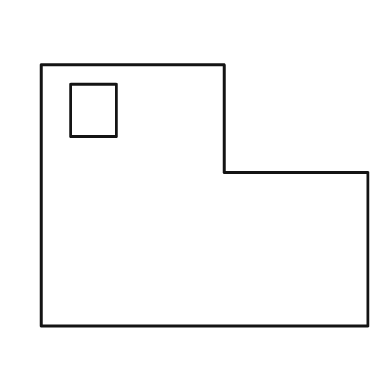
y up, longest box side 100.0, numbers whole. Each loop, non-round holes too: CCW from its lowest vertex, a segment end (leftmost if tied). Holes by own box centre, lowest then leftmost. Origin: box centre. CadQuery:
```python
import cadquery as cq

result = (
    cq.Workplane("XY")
    .moveTo(-50.0, -40.0)
    .lineTo(50.0, -40.0)
    .lineTo(50.0, 7.0)
    .lineTo(6.0, 7.0)
    .lineTo(6.0, 40.0)
    .lineTo(-50.0, 40.0)
    .close()
    .moveTo(-41.0, 18.0)
    .lineTo(-27.0, 18.0)
    .lineTo(-27.0, 34.0)
    .lineTo(-41.0, 34.0)
    .close()
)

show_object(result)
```